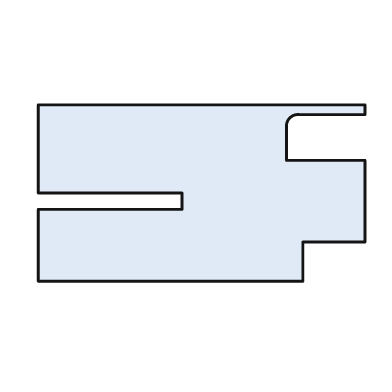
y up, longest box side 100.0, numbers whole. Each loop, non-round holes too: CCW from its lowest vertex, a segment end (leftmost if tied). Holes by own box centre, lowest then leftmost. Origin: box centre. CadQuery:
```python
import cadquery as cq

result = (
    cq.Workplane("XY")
    .moveTo(-50.0, -27.0)
    .lineTo(31.0, -27.0)
    .lineTo(31.0, -15.0)
    .lineTo(50.0, -15.0)
    .lineTo(50.0, 10.0)
    .lineTo(26.0, 10.0)
    .lineTo(26.0, 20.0)
    .threePointArc((27.0, 23.0), (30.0, 24.0))
    .lineTo(50.0, 24.0)
    .lineTo(50.0, 27.0)
    .lineTo(-50.0, 27.0)
    .lineTo(-50.0, 0.0)
    .lineTo(-6.0, 0.0)
    .lineTo(-6.0, -5.0)
    .lineTo(-50.0, -5.0)
    .close()
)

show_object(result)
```